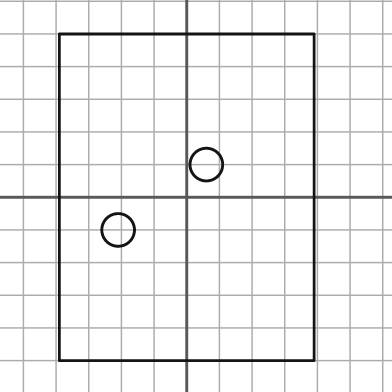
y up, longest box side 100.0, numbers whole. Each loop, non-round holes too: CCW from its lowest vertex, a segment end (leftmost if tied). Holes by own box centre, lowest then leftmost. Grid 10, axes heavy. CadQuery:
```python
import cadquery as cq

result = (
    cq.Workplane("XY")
    .moveTo(-39.0, -50.0)
    .lineTo(39.0, -50.0)
    .lineTo(39.0, 50.0)
    .lineTo(-39.0, 50.0)
    .close()
    .moveTo(-21.0, -10.0)
    .circle(5.0)
    .moveTo(6.0, 10.0)
    .circle(5.0)
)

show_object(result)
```